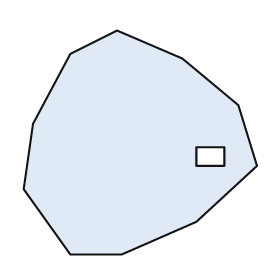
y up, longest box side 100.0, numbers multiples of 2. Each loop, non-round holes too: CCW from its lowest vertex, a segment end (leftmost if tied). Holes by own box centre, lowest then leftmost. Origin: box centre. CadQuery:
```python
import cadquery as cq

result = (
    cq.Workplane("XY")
    .moveTo(-30.0, -48.0)
    .lineTo(-8.0, -48.0)
    .lineTo(24.0, -34.0)
    .lineTo(50.0, -10.0)
    .lineTo(42.0, 16.0)
    .lineTo(18.0, 36.0)
    .lineTo(-10.0, 48.0)
    .lineTo(-30.0, 38.0)
    .lineTo(-46.0, 8.0)
    .lineTo(-50.0, -20.0)
    .close()
    .moveTo(24.0, -10.0)
    .lineTo(36.0, -10.0)
    .lineTo(36.0, -2.0)
    .lineTo(24.0, -2.0)
    .close()
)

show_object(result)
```